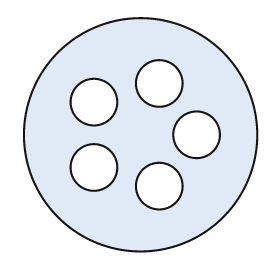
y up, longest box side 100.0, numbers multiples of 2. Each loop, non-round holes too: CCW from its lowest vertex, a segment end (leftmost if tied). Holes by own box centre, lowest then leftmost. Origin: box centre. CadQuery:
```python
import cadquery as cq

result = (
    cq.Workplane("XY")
    .moveTo(0.0, 0.0)
    .circle(50.0)
    .moveTo(8.0, -22.0)
    .circle(10.0)
    .moveTo(-20.0, -14.0)
    .circle(10.0)
    .moveTo(24.0, 0.0)
    .circle(10.0)
    .moveTo(-20.0, 14.0)
    .circle(10.0)
    .moveTo(8.0, 22.0)
    .circle(10.0)
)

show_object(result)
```